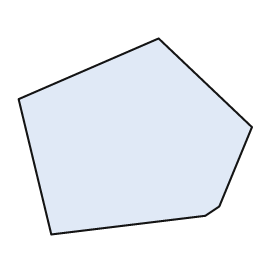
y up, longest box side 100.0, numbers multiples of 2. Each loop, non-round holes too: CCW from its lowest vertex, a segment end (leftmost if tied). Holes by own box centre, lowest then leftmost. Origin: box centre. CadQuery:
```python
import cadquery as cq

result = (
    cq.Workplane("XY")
    .moveTo(-36.0, -42.0)
    .lineTo(30.0, -34.0)
    .lineTo(36.0, -30.0)
    .lineTo(50.0, 4.0)
    .lineTo(10.0, 42.0)
    .lineTo(-50.0, 16.0)
    .close()
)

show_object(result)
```